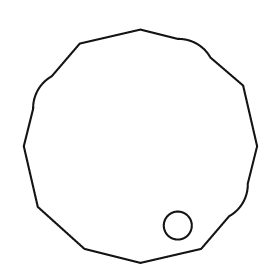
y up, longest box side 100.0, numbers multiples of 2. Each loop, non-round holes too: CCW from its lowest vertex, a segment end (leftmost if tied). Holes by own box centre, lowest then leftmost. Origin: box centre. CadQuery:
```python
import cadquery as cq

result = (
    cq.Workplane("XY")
    .moveTo(0.0, -50.0)
    .lineTo(26.0, -44.0)
    .lineTo(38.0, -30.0)
    .threePointArc((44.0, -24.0), (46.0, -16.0))
    .lineTo(50.0, 0.0)
    .lineTo(44.0, 26.0)
    .lineTo(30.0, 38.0)
    .threePointArc((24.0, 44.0), (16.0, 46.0))
    .lineTo(0.0, 50.0)
    .lineTo(-26.0, 44.0)
    .lineTo(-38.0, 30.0)
    .threePointArc((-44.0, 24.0), (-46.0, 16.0))
    .lineTo(-50.0, 0.0)
    .lineTo(-44.0, -26.0)
    .lineTo(-24.0, -44.0)
    .close()
    .moveTo(16.0, -34.0)
    .circle(6.0)
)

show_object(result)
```